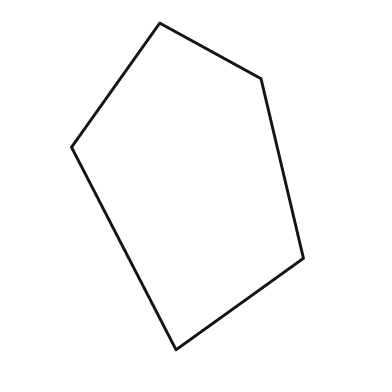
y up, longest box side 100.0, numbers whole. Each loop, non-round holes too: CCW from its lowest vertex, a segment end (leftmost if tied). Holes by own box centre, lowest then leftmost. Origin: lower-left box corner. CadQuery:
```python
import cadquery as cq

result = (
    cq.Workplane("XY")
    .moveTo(32.0, 0.0)
    .lineTo(71.0, 28.0)
    .lineTo(58.0, 83.0)
    .lineTo(27.0, 100.0)
    .lineTo(0.0, 62.0)
    .close()
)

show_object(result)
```